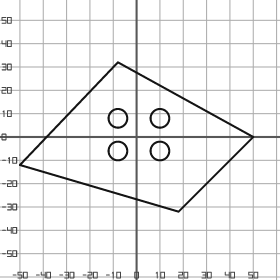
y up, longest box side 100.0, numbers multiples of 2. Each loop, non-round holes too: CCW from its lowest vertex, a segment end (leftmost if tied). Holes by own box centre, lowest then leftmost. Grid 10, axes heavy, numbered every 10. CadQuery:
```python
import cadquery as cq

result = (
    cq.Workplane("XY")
    .moveTo(18.0, -32.0)
    .lineTo(50.0, 0.0)
    .lineTo(-8.0, 32.0)
    .lineTo(-50.0, -12.0)
    .close()
    .moveTo(-8.0, -6.0)
    .circle(4.0)
    .moveTo(10.0, -6.0)
    .circle(4.0)
    .moveTo(-8.0, 8.0)
    .circle(4.0)
    .moveTo(10.0, 8.0)
    .circle(4.0)
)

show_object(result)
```